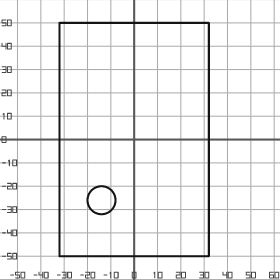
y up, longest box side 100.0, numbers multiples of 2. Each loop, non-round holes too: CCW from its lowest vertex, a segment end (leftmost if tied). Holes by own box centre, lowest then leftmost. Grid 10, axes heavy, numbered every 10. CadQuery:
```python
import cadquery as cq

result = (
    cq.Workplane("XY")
    .moveTo(-32.0, -50.0)
    .lineTo(32.0, -50.0)
    .lineTo(32.0, 50.0)
    .lineTo(-32.0, 50.0)
    .close()
    .moveTo(-14.0, -26.0)
    .circle(6.0)
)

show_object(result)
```